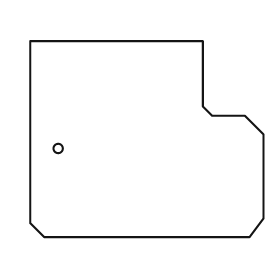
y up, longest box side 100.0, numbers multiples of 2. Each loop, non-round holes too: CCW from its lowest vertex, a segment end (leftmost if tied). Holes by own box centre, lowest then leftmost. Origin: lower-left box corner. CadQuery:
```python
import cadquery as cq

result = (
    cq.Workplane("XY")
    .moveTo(6.0, 0.0)
    .lineTo(94.0, 0.0)
    .lineTo(100.0, 8.0)
    .lineTo(100.0, 44.0)
    .lineTo(92.0, 52.0)
    .lineTo(78.0, 52.0)
    .lineTo(74.0, 56.0)
    .lineTo(74.0, 84.0)
    .lineTo(0.0, 84.0)
    .lineTo(0.0, 6.0)
    .close()
    .moveTo(12.0, 38.0)
    .circle(2.0)
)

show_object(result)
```